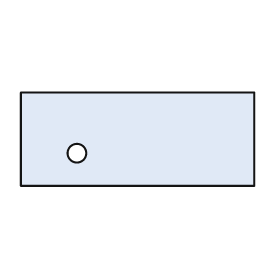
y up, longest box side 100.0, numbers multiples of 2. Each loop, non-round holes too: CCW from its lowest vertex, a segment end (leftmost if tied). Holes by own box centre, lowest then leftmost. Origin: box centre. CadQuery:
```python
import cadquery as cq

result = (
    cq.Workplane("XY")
    .moveTo(-50.0, -20.0)
    .lineTo(50.0, -20.0)
    .lineTo(50.0, 20.0)
    .lineTo(-50.0, 20.0)
    .close()
    .moveTo(-26.0, -6.0)
    .circle(4.0)
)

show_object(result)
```